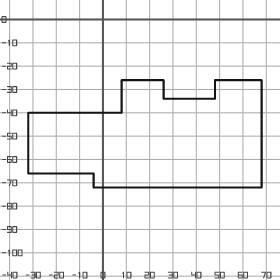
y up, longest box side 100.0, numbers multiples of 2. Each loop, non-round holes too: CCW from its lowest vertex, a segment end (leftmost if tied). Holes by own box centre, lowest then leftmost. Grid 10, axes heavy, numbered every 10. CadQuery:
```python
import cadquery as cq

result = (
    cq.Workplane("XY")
    .moveTo(-4.0, -72.0)
    .lineTo(68.0, -72.0)
    .lineTo(68.0, -26.0)
    .lineTo(48.0, -26.0)
    .lineTo(48.0, -34.0)
    .lineTo(26.0, -34.0)
    .lineTo(26.0, -26.0)
    .lineTo(8.0, -26.0)
    .lineTo(8.0, -40.0)
    .lineTo(-32.0, -40.0)
    .lineTo(-32.0, -66.0)
    .lineTo(-4.0, -66.0)
    .close()
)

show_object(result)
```